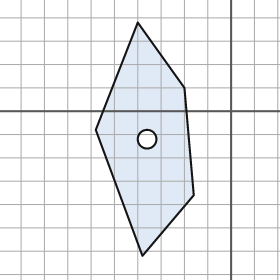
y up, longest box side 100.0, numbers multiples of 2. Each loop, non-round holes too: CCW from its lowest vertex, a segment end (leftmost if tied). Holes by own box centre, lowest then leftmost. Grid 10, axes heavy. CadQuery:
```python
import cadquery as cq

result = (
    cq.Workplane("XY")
    .moveTo(-38.0, -62.0)
    .lineTo(-16.0, -36.0)
    .lineTo(-20.0, 10.0)
    .lineTo(-40.0, 38.0)
    .lineTo(-58.0, -8.0)
    .close()
    .moveTo(-36.0, -12.0)
    .circle(4.0)
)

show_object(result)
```